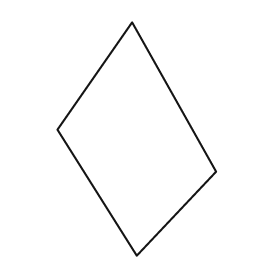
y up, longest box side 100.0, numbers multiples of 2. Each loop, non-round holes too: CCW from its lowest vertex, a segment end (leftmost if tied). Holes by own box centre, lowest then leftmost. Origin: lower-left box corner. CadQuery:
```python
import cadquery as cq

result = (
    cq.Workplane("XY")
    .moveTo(34.0, 0.0)
    .lineTo(68.0, 36.0)
    .lineTo(32.0, 100.0)
    .lineTo(0.0, 54.0)
    .close()
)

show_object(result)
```